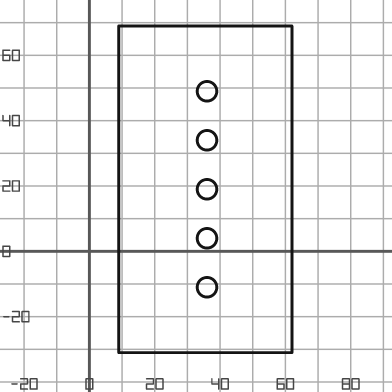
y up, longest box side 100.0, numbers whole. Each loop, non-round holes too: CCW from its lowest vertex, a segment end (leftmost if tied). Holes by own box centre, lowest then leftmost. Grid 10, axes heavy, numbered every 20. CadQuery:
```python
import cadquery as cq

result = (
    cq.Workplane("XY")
    .moveTo(9.0, -31.0)
    .lineTo(62.0, -31.0)
    .lineTo(62.0, 69.0)
    .lineTo(9.0, 69.0)
    .close()
    .moveTo(36.0, -11.0)
    .circle(3.0)
    .moveTo(36.0, 4.0)
    .circle(3.0)
    .moveTo(36.0, 19.0)
    .circle(3.0)
    .moveTo(36.0, 34.0)
    .circle(3.0)
    .moveTo(36.0, 49.0)
    .circle(3.0)
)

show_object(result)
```